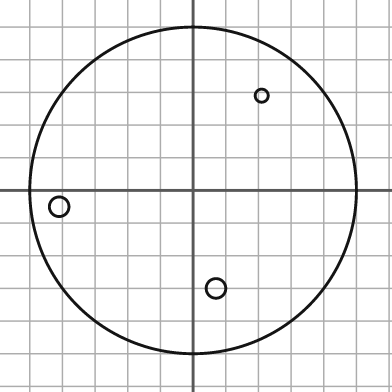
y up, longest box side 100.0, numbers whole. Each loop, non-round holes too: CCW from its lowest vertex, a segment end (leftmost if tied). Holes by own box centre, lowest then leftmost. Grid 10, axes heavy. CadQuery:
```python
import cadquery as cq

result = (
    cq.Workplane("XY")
    .moveTo(0.0, 0.0)
    .circle(50.0)
    .moveTo(7.0, -30.0)
    .circle(3.0)
    .moveTo(-41.0, -5.0)
    .circle(3.0)
    .moveTo(21.0, 29.0)
    .circle(2.0)
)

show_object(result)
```